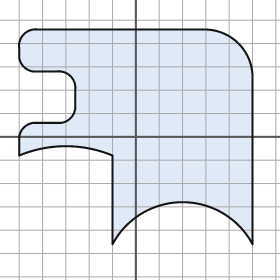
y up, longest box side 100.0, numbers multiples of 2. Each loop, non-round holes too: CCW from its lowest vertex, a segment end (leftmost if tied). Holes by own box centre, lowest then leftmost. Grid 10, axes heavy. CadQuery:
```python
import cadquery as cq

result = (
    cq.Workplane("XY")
    .moveTo(-10.0, -46.0)
    .threePointArc((20.0, -28.0), (50.0, -46.0))
    .lineTo(50.0, 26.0)
    .threePointArc((44.0, 40.0), (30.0, 46.0))
    .lineTo(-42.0, 46.0)
    .threePointArc((-48.0, 44.0), (-50.0, 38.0))
    .lineTo(-50.0, 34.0)
    .threePointArc((-48.0, 30.0), (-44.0, 28.0))
    .lineTo(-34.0, 28.0)
    .threePointArc((-28.0, 26.0), (-26.0, 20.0))
    .lineTo(-26.0, 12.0)
    .threePointArc((-28.0, 8.0), (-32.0, 6.0))
    .lineTo(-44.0, 6.0)
    .threePointArc((-48.0, 4.0), (-50.0, 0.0))
    .lineTo(-50.0, -8.0)
    .threePointArc((-30.0, -4.0), (-10.0, -8.0))
    .close()
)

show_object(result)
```